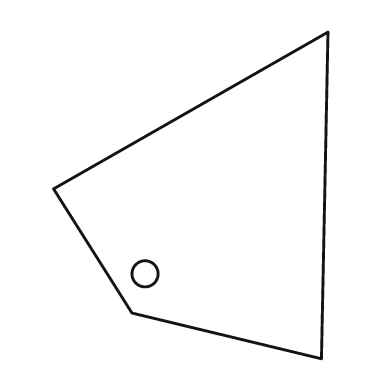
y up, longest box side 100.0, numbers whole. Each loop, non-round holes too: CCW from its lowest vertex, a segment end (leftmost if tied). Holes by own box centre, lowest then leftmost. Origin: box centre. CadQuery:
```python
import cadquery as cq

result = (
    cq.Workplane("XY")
    .moveTo(40.0, -50.0)
    .lineTo(42.0, 50.0)
    .lineTo(-42.0, 2.0)
    .lineTo(-18.0, -36.0)
    .close()
    .moveTo(-14.0, -24.0)
    .circle(4.0)
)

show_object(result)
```